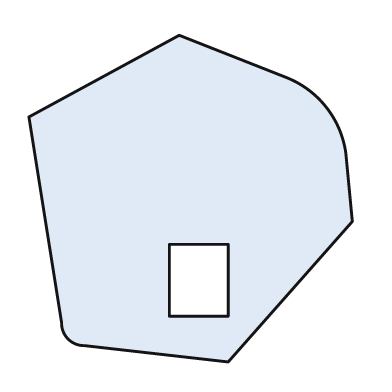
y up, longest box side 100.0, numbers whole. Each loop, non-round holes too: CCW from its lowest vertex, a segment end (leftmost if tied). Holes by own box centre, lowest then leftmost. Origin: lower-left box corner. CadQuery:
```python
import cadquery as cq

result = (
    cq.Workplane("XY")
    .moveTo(61.0, 0.0)
    .lineTo(99.0, 43.0)
    .lineTo(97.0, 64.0)
    .threePointArc((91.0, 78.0), (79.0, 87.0))
    .lineTo(46.0, 100.0)
    .lineTo(0.0, 75.0)
    .lineTo(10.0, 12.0)
    .threePointArc((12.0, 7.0), (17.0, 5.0))
    .close()
    .moveTo(43.0, 14.0)
    .lineTo(61.0, 14.0)
    .lineTo(61.0, 36.0)
    .lineTo(43.0, 36.0)
    .close()
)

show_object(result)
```